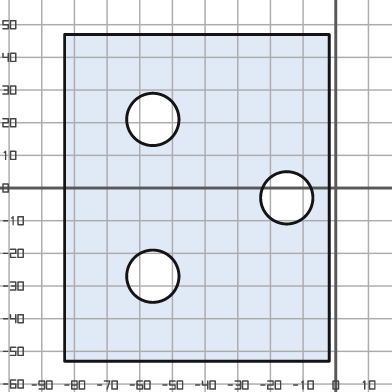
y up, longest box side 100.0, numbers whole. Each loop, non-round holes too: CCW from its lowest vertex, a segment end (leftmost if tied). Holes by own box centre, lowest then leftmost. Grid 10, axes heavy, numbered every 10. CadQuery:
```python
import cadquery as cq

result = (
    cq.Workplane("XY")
    .moveTo(-83.0, -53.0)
    .lineTo(-2.0, -53.0)
    .lineTo(-2.0, 47.0)
    .lineTo(-83.0, 47.0)
    .close()
    .moveTo(-56.0, -27.0)
    .circle(8.0)
    .moveTo(-15.0, -3.0)
    .circle(8.0)
    .moveTo(-56.0, 21.0)
    .circle(8.0)
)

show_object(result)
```